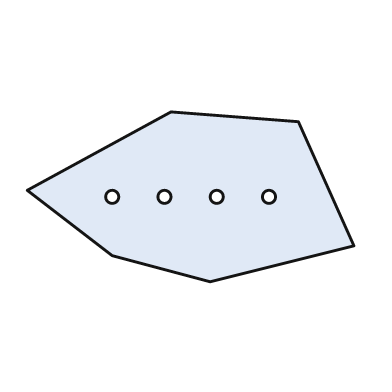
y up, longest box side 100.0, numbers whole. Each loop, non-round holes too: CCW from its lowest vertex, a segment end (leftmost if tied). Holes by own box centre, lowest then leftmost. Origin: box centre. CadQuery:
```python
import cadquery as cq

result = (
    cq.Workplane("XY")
    .moveTo(6.0, -26.0)
    .lineTo(50.0, -15.0)
    .lineTo(33.0, 23.0)
    .lineTo(-6.0, 26.0)
    .lineTo(-50.0, 2.0)
    .lineTo(-24.0, -18.0)
    .close()
    .moveTo(-24.0, 0.0)
    .circle(2.0)
    .moveTo(-8.0, 0.0)
    .circle(2.0)
    .moveTo(8.0, 0.0)
    .circle(2.0)
    .moveTo(24.0, 0.0)
    .circle(2.0)
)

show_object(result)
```